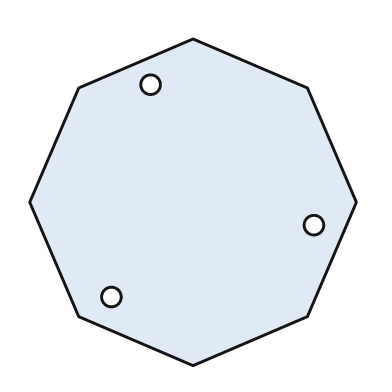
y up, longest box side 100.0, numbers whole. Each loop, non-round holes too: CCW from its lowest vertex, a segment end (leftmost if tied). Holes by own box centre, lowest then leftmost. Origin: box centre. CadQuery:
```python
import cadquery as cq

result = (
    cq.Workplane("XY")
    .moveTo(0.0, -50.0)
    .lineTo(35.0, -35.0)
    .lineTo(50.0, 0.0)
    .lineTo(35.0, 35.0)
    .lineTo(0.0, 50.0)
    .lineTo(-35.0, 35.0)
    .lineTo(-50.0, 0.0)
    .lineTo(-35.0, -35.0)
    .close()
    .moveTo(-25.0, -29.0)
    .circle(3.0)
    .moveTo(37.0, -7.0)
    .circle(3.0)
    .moveTo(-13.0, 36.0)
    .circle(3.0)
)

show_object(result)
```